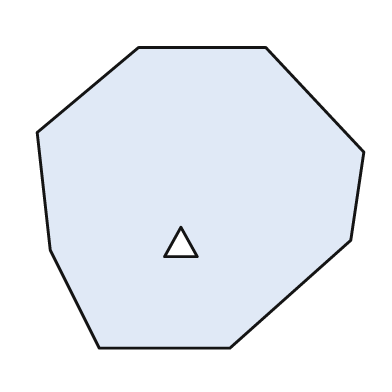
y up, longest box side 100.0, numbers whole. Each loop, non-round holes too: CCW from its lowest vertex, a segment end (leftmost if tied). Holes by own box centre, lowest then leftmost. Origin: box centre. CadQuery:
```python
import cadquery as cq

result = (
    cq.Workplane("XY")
    .moveTo(-31.0, -46.0)
    .lineTo(9.0, -46.0)
    .lineTo(46.0, -13.0)
    .lineTo(50.0, 14.0)
    .lineTo(20.0, 46.0)
    .lineTo(-19.0, 46.0)
    .lineTo(-50.0, 20.0)
    .lineTo(-46.0, -16.0)
    .close()
    .moveTo(-11.0, -18.0)
    .lineTo(-1.0, -18.0)
    .lineTo(-6.0, -9.0)
    .close()
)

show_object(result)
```